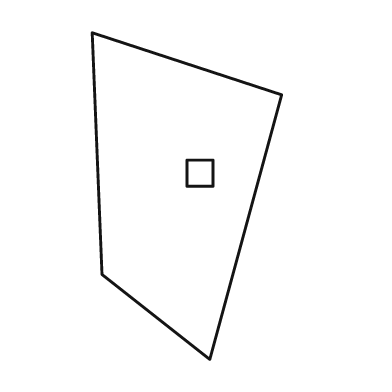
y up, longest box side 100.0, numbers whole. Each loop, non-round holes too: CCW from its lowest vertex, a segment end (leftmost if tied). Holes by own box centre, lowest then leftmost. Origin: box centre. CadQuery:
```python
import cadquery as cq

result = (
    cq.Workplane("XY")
    .moveTo(7.0, -50.0)
    .lineTo(29.0, 31.0)
    .lineTo(-29.0, 50.0)
    .lineTo(-26.0, -24.0)
    .close()
    .moveTo(0.0, 3.0)
    .lineTo(8.0, 3.0)
    .lineTo(8.0, 11.0)
    .lineTo(0.0, 11.0)
    .close()
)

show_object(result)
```